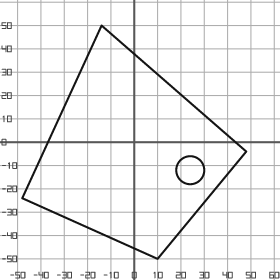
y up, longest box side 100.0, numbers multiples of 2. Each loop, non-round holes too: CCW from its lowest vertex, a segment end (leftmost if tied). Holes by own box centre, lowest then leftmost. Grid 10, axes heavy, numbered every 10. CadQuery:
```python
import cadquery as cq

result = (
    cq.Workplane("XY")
    .moveTo(10.0, -50.0)
    .lineTo(48.0, -4.0)
    .lineTo(-14.0, 50.0)
    .lineTo(-48.0, -24.0)
    .close()
    .moveTo(24.0, -12.0)
    .circle(6.0)
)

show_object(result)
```